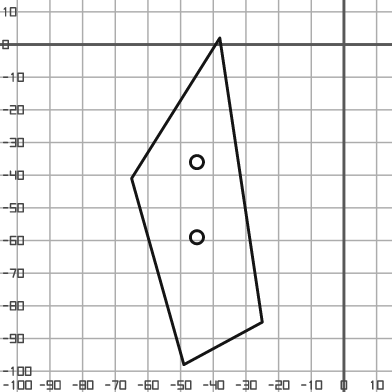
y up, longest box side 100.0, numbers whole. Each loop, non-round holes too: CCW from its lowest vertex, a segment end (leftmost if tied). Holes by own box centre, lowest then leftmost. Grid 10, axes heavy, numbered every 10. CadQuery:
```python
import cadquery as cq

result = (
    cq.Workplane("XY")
    .moveTo(-49.0, -98.0)
    .lineTo(-25.0, -85.0)
    .lineTo(-38.0, 2.0)
    .lineTo(-65.0, -41.0)
    .close()
    .moveTo(-45.0, -59.0)
    .circle(2.0)
    .moveTo(-45.0, -36.0)
    .circle(2.0)
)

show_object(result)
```